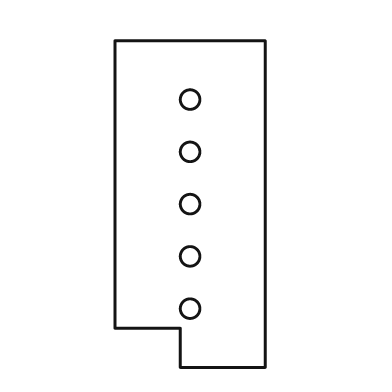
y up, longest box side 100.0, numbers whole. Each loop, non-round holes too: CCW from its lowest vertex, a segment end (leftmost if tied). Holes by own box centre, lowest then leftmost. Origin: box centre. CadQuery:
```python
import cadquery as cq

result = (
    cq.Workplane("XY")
    .moveTo(-3.0, -50.0)
    .lineTo(23.0, -50.0)
    .lineTo(23.0, 50.0)
    .lineTo(-23.0, 50.0)
    .lineTo(-23.0, -38.0)
    .lineTo(-3.0, -38.0)
    .close()
    .moveTo(0.0, -32.0)
    .circle(3.0)
    .moveTo(0.0, -16.0)
    .circle(3.0)
    .moveTo(0.0, 0.0)
    .circle(3.0)
    .moveTo(0.0, 16.0)
    .circle(3.0)
    .moveTo(0.0, 32.0)
    .circle(3.0)
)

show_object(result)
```